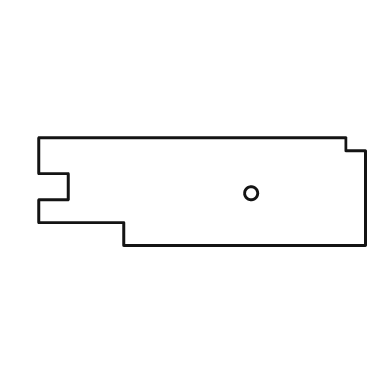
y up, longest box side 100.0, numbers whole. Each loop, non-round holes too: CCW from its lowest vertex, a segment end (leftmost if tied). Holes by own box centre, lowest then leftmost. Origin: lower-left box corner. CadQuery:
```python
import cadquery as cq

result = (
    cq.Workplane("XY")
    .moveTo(26.0, 0.0)
    .lineTo(100.0, 0.0)
    .lineTo(100.0, 29.0)
    .lineTo(94.0, 29.0)
    .lineTo(94.0, 33.0)
    .lineTo(0.0, 33.0)
    .lineTo(0.0, 22.0)
    .lineTo(9.0, 22.0)
    .lineTo(9.0, 14.0)
    .lineTo(0.0, 14.0)
    .lineTo(0.0, 7.0)
    .lineTo(26.0, 7.0)
    .close()
    .moveTo(65.0, 16.0)
    .circle(2.0)
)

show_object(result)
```